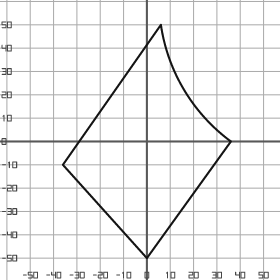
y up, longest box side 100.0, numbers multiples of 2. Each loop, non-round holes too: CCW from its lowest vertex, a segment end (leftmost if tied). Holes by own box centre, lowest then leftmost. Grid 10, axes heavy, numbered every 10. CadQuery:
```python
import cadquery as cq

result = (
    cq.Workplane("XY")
    .moveTo(0.0, -50.0)
    .lineTo(36.0, 0.0)
    .threePointArc((16.0, 22.0), (6.0, 50.0))
    .lineTo(-36.0, -10.0)
    .close()
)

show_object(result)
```